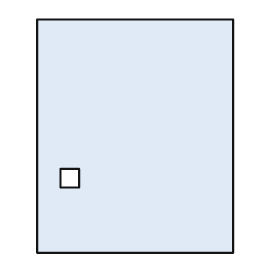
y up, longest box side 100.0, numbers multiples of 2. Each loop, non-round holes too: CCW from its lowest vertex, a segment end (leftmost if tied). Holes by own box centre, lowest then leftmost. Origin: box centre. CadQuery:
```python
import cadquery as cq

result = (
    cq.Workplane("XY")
    .moveTo(-42.0, -50.0)
    .lineTo(42.0, -50.0)
    .lineTo(42.0, 50.0)
    .lineTo(-42.0, 50.0)
    .close()
    .moveTo(-32.0, -22.0)
    .lineTo(-24.0, -22.0)
    .lineTo(-24.0, -14.0)
    .lineTo(-32.0, -14.0)
    .close()
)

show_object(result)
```